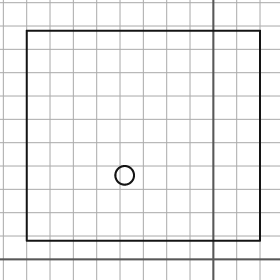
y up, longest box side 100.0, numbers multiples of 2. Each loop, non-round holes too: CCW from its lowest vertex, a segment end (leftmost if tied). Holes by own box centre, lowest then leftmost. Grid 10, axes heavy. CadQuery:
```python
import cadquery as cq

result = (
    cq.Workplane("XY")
    .moveTo(-80.0, 8.0)
    .lineTo(20.0, 8.0)
    .lineTo(20.0, 98.0)
    .lineTo(-80.0, 98.0)
    .close()
    .moveTo(-38.0, 36.0)
    .circle(4.0)
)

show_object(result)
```